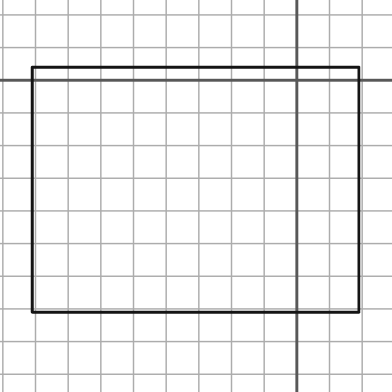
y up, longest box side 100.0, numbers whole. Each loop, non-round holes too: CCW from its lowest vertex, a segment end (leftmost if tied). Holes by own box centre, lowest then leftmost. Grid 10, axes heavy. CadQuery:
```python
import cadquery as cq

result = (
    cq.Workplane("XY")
    .moveTo(-81.0, -71.0)
    .lineTo(19.0, -71.0)
    .lineTo(19.0, 4.0)
    .lineTo(-81.0, 4.0)
    .close()
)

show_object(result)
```